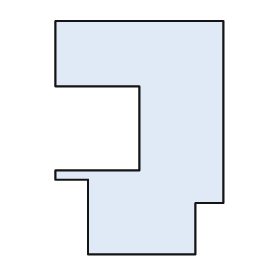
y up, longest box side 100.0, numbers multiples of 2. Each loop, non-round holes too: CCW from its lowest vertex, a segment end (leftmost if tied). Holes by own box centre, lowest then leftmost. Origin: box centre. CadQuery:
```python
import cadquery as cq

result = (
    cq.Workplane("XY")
    .moveTo(-22.0, -50.0)
    .lineTo(24.0, -50.0)
    .lineTo(24.0, -28.0)
    .lineTo(36.0, -28.0)
    .lineTo(36.0, 50.0)
    .lineTo(-36.0, 50.0)
    .lineTo(-36.0, 22.0)
    .lineTo(0.0, 22.0)
    .lineTo(0.0, -14.0)
    .lineTo(-36.0, -14.0)
    .lineTo(-36.0, -18.0)
    .lineTo(-22.0, -18.0)
    .close()
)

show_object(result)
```